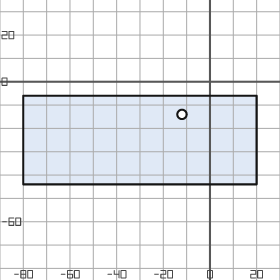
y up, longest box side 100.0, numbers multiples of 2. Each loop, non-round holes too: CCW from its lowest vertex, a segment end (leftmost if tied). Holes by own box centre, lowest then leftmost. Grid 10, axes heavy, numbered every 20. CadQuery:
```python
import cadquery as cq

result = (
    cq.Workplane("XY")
    .moveTo(-80.0, -44.0)
    .lineTo(20.0, -44.0)
    .lineTo(20.0, -6.0)
    .lineTo(-80.0, -6.0)
    .close()
    .moveTo(-12.0, -14.0)
    .circle(2.0)
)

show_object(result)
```